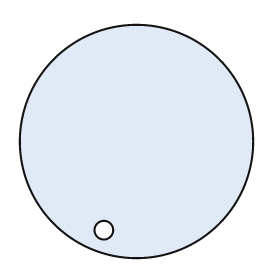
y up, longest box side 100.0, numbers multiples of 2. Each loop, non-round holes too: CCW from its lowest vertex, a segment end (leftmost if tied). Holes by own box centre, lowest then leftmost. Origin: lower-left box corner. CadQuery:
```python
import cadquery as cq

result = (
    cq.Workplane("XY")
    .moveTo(50.0, 50.0)
    .circle(50.0)
    .moveTo(36.0, 12.0)
    .circle(4.0)
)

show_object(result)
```